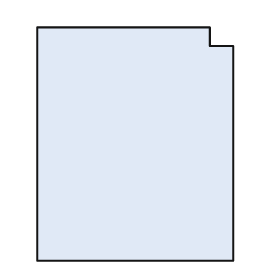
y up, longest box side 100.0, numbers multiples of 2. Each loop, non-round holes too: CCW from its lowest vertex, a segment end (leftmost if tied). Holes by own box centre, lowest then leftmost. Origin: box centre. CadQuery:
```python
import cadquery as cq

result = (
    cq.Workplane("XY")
    .moveTo(-42.0, -50.0)
    .lineTo(42.0, -50.0)
    .lineTo(42.0, 42.0)
    .lineTo(32.0, 42.0)
    .lineTo(32.0, 50.0)
    .lineTo(-42.0, 50.0)
    .close()
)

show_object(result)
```